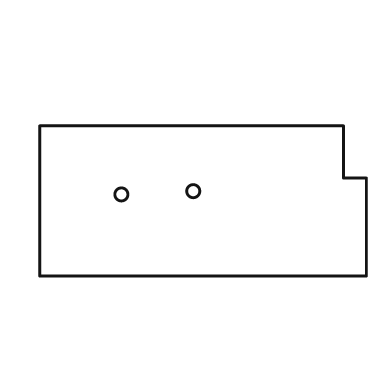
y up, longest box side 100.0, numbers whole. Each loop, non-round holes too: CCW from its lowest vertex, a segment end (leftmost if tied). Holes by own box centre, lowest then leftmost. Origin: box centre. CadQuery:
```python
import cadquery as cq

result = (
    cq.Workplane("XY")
    .moveTo(-50.0, -23.0)
    .lineTo(50.0, -23.0)
    .lineTo(50.0, 7.0)
    .lineTo(43.0, 7.0)
    .lineTo(43.0, 23.0)
    .lineTo(-50.0, 23.0)
    .close()
    .moveTo(-25.0, 2.0)
    .circle(2.0)
    .moveTo(-3.0, 3.0)
    .circle(2.0)
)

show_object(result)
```